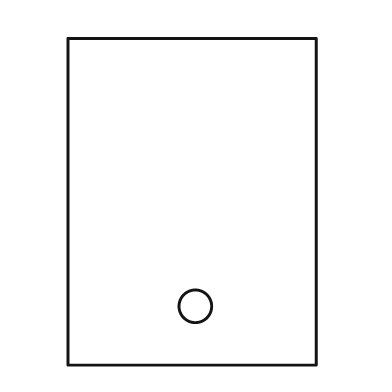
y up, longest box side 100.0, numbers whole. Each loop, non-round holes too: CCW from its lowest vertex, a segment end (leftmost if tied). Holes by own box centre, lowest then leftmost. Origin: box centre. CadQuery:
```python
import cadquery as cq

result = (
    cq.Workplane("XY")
    .moveTo(-38.0, -50.0)
    .lineTo(38.0, -50.0)
    .lineTo(38.0, 50.0)
    .lineTo(-38.0, 50.0)
    .close()
    .moveTo(1.0, -32.0)
    .circle(5.0)
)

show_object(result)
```